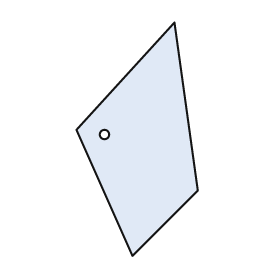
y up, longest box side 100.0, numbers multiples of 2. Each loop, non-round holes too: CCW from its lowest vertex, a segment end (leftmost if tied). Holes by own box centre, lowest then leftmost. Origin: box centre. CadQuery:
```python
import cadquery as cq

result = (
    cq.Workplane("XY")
    .moveTo(-2.0, -50.0)
    .lineTo(26.0, -22.0)
    .lineTo(16.0, 50.0)
    .lineTo(-26.0, 4.0)
    .close()
    .moveTo(-14.0, 2.0)
    .circle(2.0)
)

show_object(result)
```